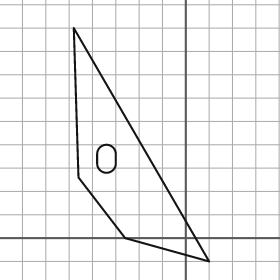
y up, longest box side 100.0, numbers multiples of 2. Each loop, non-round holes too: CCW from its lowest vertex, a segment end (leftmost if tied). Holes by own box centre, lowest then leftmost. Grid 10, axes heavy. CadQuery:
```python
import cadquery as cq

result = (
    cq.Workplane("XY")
    .moveTo(10.0, -10.0)
    .lineTo(-48.0, 90.0)
    .lineTo(-46.0, 26.0)
    .lineTo(-26.0, 0.0)
    .close()
    .moveTo(-38.0, 32.0)
    .threePointArc((-34.0, 28.0), (-30.0, 32.0))
    .lineTo(-30.0, 36.0)
    .threePointArc((-34.0, 40.0), (-38.0, 36.0))
    .close()
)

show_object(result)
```